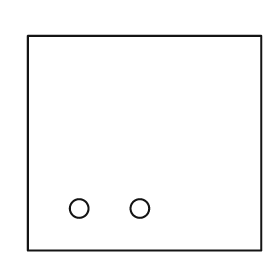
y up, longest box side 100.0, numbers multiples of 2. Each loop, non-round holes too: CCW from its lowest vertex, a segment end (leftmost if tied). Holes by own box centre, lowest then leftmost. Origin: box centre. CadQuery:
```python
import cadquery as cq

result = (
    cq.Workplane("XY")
    .moveTo(-50.0, -46.0)
    .lineTo(50.0, -46.0)
    .lineTo(50.0, 46.0)
    .lineTo(-50.0, 46.0)
    .close()
    .moveTo(-28.0, -28.0)
    .circle(4.0)
    .moveTo(-2.0, -28.0)
    .circle(4.0)
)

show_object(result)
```